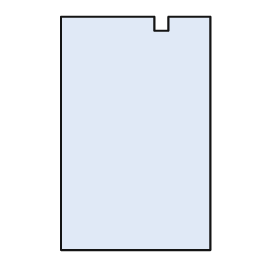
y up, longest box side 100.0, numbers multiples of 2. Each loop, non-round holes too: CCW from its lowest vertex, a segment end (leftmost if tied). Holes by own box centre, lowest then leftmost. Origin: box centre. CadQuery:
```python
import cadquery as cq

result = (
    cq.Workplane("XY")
    .moveTo(-32.0, -50.0)
    .lineTo(32.0, -50.0)
    .lineTo(32.0, 50.0)
    .lineTo(14.0, 50.0)
    .lineTo(14.0, 44.0)
    .lineTo(8.0, 44.0)
    .lineTo(8.0, 50.0)
    .lineTo(-32.0, 50.0)
    .close()
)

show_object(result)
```